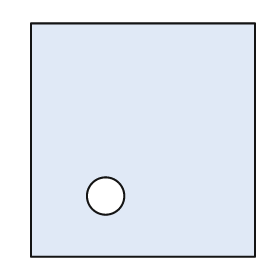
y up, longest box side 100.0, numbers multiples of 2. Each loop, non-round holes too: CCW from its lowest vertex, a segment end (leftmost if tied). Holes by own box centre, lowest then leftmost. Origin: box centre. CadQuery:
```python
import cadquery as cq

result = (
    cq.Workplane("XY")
    .moveTo(-48.0, -50.0)
    .lineTo(48.0, -50.0)
    .lineTo(48.0, 50.0)
    .lineTo(-48.0, 50.0)
    .close()
    .moveTo(-16.0, -24.0)
    .circle(8.0)
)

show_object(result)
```